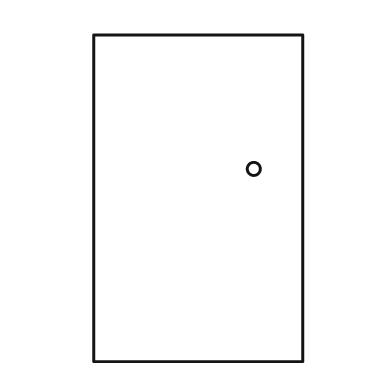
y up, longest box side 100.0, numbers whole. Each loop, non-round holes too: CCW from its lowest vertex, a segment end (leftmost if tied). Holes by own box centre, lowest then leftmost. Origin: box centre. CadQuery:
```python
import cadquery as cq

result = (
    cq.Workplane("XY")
    .moveTo(-32.0, -50.0)
    .lineTo(32.0, -50.0)
    .lineTo(32.0, 50.0)
    .lineTo(-32.0, 50.0)
    .close()
    .moveTo(17.0, 9.0)
    .circle(2.0)
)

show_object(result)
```